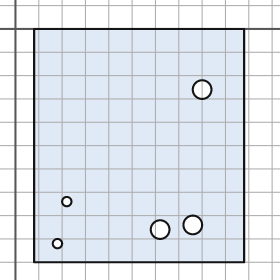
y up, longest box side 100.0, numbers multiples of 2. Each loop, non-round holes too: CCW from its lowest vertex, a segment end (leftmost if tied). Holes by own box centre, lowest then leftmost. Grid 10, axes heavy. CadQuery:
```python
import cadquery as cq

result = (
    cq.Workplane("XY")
    .moveTo(8.0, -100.0)
    .lineTo(98.0, -100.0)
    .lineTo(98.0, 0.0)
    .lineTo(8.0, 0.0)
    .close()
    .moveTo(18.0, -92.0)
    .circle(2.0)
    .moveTo(62.0, -86.0)
    .circle(4.0)
    .moveTo(76.0, -84.0)
    .circle(4.0)
    .moveTo(22.0, -74.0)
    .circle(2.0)
    .moveTo(80.0, -26.0)
    .circle(4.0)
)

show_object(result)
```